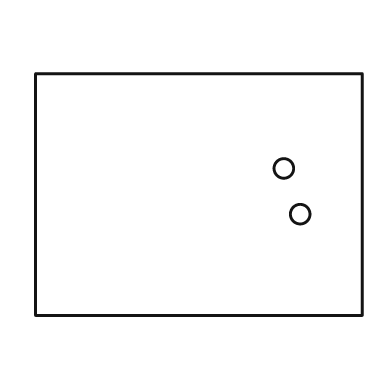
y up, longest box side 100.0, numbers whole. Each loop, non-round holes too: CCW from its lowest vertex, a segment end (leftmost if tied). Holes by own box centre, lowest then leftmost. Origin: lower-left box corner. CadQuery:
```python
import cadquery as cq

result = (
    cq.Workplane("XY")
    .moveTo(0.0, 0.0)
    .lineTo(100.0, 0.0)
    .lineTo(100.0, 74.0)
    .lineTo(0.0, 74.0)
    .close()
    .moveTo(81.0, 31.0)
    .circle(3.0)
    .moveTo(76.0, 45.0)
    .circle(3.0)
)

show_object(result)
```